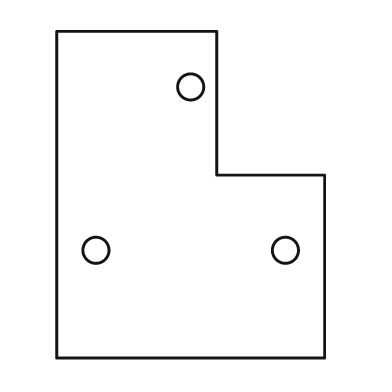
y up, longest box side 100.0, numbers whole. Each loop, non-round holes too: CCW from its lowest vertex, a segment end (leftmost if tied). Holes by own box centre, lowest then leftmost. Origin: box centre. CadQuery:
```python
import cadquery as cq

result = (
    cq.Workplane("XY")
    .moveTo(-41.0, -50.0)
    .lineTo(41.0, -50.0)
    .lineTo(41.0, 6.0)
    .lineTo(8.0, 6.0)
    .lineTo(8.0, 50.0)
    .lineTo(-41.0, 50.0)
    .close()
    .moveTo(-29.0, -17.0)
    .circle(4.0)
    .moveTo(29.0, -17.0)
    .circle(4.0)
    .moveTo(0.0, 33.0)
    .circle(4.0)
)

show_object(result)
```